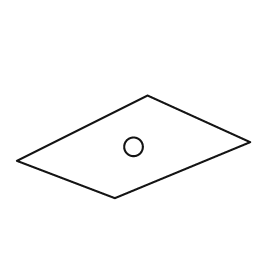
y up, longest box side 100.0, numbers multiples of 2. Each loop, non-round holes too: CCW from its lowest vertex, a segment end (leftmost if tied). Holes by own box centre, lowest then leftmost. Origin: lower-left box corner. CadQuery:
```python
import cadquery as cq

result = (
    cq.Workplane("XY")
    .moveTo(42.0, 0.0)
    .lineTo(100.0, 24.0)
    .lineTo(56.0, 44.0)
    .lineTo(0.0, 16.0)
    .close()
    .moveTo(50.0, 22.0)
    .circle(4.0)
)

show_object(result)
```